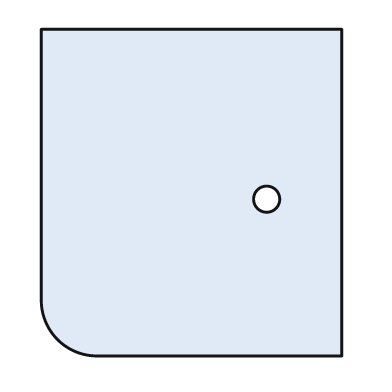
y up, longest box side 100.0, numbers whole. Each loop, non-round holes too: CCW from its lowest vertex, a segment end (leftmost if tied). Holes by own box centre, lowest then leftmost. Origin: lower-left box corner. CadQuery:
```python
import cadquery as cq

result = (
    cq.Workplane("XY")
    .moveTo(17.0, 0.0)
    .lineTo(92.0, 0.0)
    .lineTo(92.0, 100.0)
    .lineTo(0.0, 100.0)
    .lineTo(0.0, 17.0)
    .threePointArc((5.0, 5.0), (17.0, 0.0))
    .close()
    .moveTo(69.0, 48.0)
    .circle(4.0)
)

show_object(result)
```